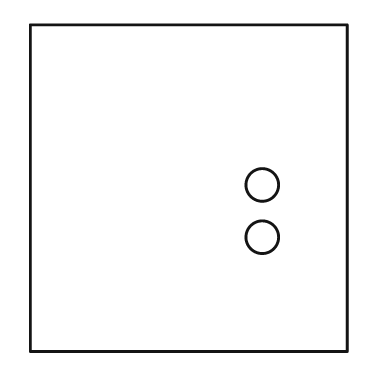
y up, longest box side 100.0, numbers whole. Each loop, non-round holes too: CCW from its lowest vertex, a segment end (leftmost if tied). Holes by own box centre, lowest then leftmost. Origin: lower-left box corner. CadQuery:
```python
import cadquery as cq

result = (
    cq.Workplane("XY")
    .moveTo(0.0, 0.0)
    .lineTo(97.0, 0.0)
    .lineTo(97.0, 100.0)
    .lineTo(0.0, 100.0)
    .close()
    .moveTo(71.0, 35.0)
    .circle(5.0)
    .moveTo(71.0, 51.0)
    .circle(5.0)
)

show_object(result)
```